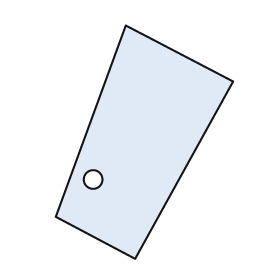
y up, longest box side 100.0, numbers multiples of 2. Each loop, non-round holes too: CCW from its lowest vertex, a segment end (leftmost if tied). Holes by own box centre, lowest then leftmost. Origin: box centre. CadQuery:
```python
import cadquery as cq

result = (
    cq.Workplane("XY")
    .moveTo(-4.0, -50.0)
    .lineTo(38.0, 26.0)
    .lineTo(-8.0, 50.0)
    .lineTo(-38.0, -32.0)
    .close()
    .moveTo(-22.0, -16.0)
    .circle(4.0)
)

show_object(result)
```